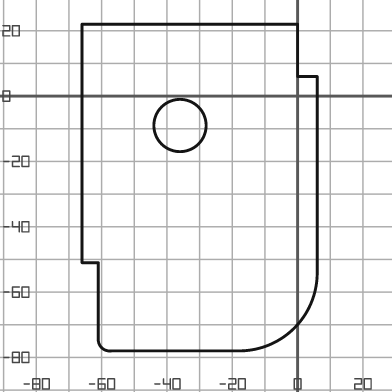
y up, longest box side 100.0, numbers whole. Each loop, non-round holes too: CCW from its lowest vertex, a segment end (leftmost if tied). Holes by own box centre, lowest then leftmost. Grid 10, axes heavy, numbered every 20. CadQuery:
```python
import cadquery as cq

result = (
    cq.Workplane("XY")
    .moveTo(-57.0, -78.0)
    .lineTo(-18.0, -78.0)
    .threePointArc((-1.0, -71.0), (6.0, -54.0))
    .lineTo(6.0, 6.0)
    .lineTo(0.0, 6.0)
    .lineTo(0.0, 22.0)
    .lineTo(-66.0, 22.0)
    .lineTo(-66.0, -51.0)
    .lineTo(-61.0, -51.0)
    .lineTo(-61.0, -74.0)
    .threePointArc((-60.0, -77.0), (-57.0, -78.0))
    .close()
    .moveTo(-36.0, -9.0)
    .circle(8.0)
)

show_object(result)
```